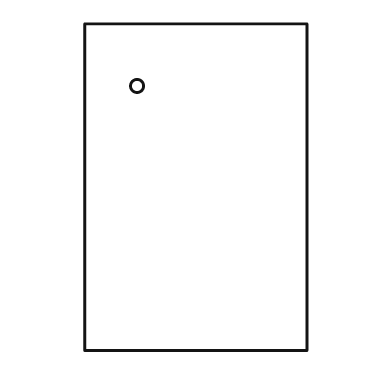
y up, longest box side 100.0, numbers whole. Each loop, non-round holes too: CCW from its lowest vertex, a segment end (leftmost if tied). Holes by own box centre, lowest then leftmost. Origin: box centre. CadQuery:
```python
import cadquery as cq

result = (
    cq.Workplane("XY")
    .moveTo(-34.0, -50.0)
    .lineTo(34.0, -50.0)
    .lineTo(34.0, 50.0)
    .lineTo(-34.0, 50.0)
    .close()
    .moveTo(-18.0, 31.0)
    .circle(2.0)
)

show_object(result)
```